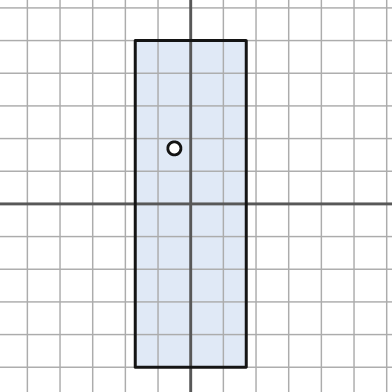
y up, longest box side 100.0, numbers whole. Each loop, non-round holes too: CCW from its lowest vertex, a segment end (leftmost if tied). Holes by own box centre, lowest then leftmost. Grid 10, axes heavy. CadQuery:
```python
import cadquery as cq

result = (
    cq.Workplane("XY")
    .moveTo(-17.0, -50.0)
    .lineTo(17.0, -50.0)
    .lineTo(17.0, 50.0)
    .lineTo(-17.0, 50.0)
    .close()
    .moveTo(-5.0, 17.0)
    .circle(2.0)
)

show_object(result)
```